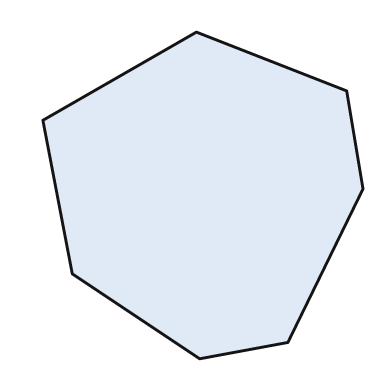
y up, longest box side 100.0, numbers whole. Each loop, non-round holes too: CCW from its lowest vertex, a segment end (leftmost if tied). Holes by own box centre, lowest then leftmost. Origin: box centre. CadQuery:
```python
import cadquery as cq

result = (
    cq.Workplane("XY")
    .moveTo(-1.0, -50.0)
    .lineTo(26.0, -45.0)
    .lineTo(49.0, 2.0)
    .lineTo(44.0, 32.0)
    .lineTo(-2.0, 50.0)
    .lineTo(-49.0, 23.0)
    .lineTo(-40.0, -24.0)
    .close()
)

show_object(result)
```